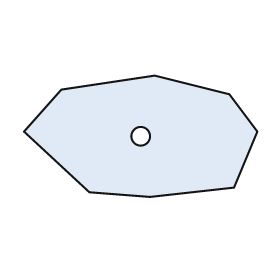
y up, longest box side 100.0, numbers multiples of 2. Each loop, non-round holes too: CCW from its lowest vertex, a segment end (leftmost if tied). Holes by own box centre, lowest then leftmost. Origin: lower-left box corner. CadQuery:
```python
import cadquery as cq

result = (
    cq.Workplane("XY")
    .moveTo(54.0, 0.0)
    .lineTo(90.0, 4.0)
    .lineTo(100.0, 28.0)
    .lineTo(88.0, 44.0)
    .lineTo(56.0, 52.0)
    .lineTo(16.0, 46.0)
    .lineTo(0.0, 28.0)
    .lineTo(28.0, 2.0)
    .close()
    .moveTo(50.0, 26.0)
    .circle(4.0)
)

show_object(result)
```